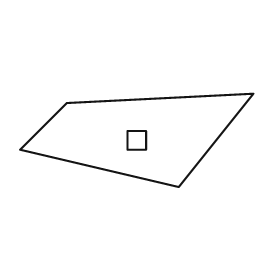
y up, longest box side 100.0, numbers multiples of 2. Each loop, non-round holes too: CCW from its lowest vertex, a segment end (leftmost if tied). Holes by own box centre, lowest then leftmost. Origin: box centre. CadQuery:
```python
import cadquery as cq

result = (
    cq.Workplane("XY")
    .moveTo(18.0, -20.0)
    .lineTo(50.0, 20.0)
    .lineTo(-30.0, 16.0)
    .lineTo(-50.0, -4.0)
    .close()
    .moveTo(-4.0, -4.0)
    .lineTo(4.0, -4.0)
    .lineTo(4.0, 4.0)
    .lineTo(-4.0, 4.0)
    .close()
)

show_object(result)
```